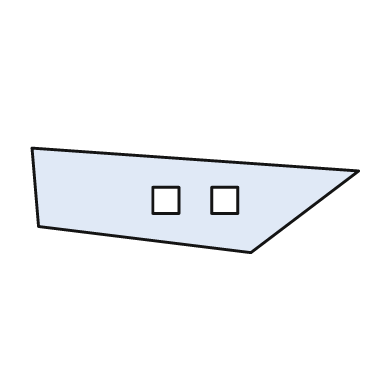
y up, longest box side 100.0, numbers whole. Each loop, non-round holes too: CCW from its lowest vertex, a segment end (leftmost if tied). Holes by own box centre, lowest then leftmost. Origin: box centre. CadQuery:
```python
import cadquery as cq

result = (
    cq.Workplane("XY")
    .moveTo(17.0, -16.0)
    .lineTo(50.0, 9.0)
    .lineTo(-50.0, 16.0)
    .lineTo(-48.0, -8.0)
    .close()
    .moveTo(-13.0, -4.0)
    .lineTo(-5.0, -4.0)
    .lineTo(-5.0, 4.0)
    .lineTo(-13.0, 4.0)
    .close()
    .moveTo(5.0, -4.0)
    .lineTo(13.0, -4.0)
    .lineTo(13.0, 4.0)
    .lineTo(5.0, 4.0)
    .close()
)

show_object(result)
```